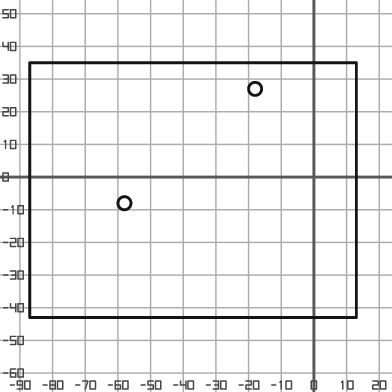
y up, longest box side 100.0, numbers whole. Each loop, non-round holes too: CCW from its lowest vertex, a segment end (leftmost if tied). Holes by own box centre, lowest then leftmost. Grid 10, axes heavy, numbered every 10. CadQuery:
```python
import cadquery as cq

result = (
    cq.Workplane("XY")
    .moveTo(-87.0, -43.0)
    .lineTo(13.0, -43.0)
    .lineTo(13.0, 35.0)
    .lineTo(-87.0, 35.0)
    .close()
    .moveTo(-58.0, -8.0)
    .circle(2.0)
    .moveTo(-18.0, 27.0)
    .circle(2.0)
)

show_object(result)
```